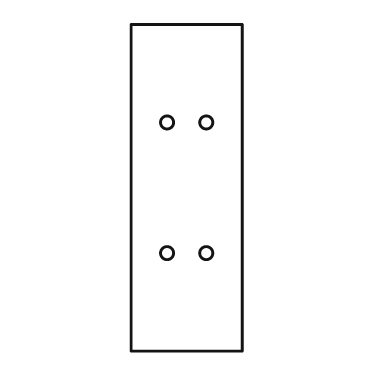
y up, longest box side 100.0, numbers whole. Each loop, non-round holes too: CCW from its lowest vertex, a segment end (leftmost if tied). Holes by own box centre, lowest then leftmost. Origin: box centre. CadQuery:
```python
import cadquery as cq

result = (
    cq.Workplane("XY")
    .moveTo(-17.0, -50.0)
    .lineTo(17.0, -50.0)
    .lineTo(17.0, 50.0)
    .lineTo(-17.0, 50.0)
    .close()
    .moveTo(-6.0, -20.0)
    .circle(2.0)
    .moveTo(6.0, -20.0)
    .circle(2.0)
    .moveTo(-6.0, 20.0)
    .circle(2.0)
    .moveTo(6.0, 20.0)
    .circle(2.0)
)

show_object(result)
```